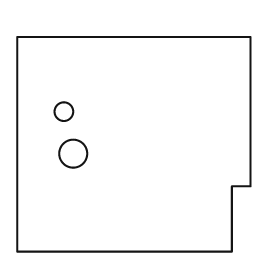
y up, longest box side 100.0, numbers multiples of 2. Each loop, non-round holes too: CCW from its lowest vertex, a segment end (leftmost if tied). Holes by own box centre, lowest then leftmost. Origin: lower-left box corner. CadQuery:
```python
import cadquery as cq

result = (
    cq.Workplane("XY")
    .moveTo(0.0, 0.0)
    .lineTo(92.0, 0.0)
    .lineTo(92.0, 28.0)
    .lineTo(100.0, 28.0)
    .lineTo(100.0, 92.0)
    .lineTo(0.0, 92.0)
    .close()
    .moveTo(24.0, 42.0)
    .circle(6.0)
    .moveTo(20.0, 60.0)
    .circle(4.0)
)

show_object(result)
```